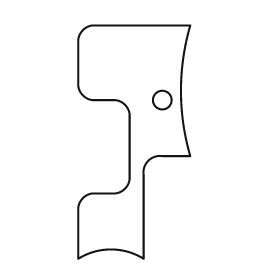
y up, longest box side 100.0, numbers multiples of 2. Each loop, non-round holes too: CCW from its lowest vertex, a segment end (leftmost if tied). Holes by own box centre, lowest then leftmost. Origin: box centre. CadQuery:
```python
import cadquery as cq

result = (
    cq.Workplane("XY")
    .moveTo(-24.0, -50.0)
    .threePointArc((-10.0, -46.0), (4.0, -50.0))
    .lineTo(4.0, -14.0)
    .threePointArc((6.0, -8.0), (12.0, -6.0))
    .lineTo(24.0, -6.0)
    .threePointArc((20.0, 22.0), (24.0, 50.0))
    .lineTo(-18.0, 50.0)
    .threePointArc((-22.0, 48.0), (-24.0, 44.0))
    .lineTo(-24.0, 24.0)
    .threePointArc((-22.0, 20.0), (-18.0, 18.0))
    .lineTo(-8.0, 18.0)
    .threePointArc((-4.0, 16.0), (-2.0, 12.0))
    .lineTo(-2.0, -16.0)
    .threePointArc((-4.0, -20.0), (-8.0, -22.0))
    .lineTo(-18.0, -22.0)
    .threePointArc((-22.0, -24.0), (-24.0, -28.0))
    .close()
    .moveTo(12.0, 18.0)
    .circle(4.0)
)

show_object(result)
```